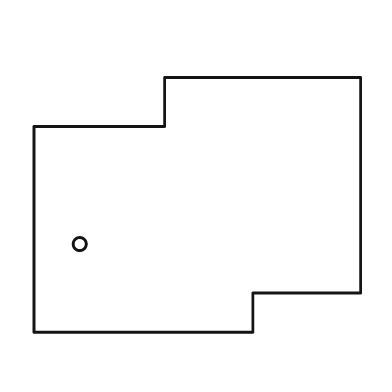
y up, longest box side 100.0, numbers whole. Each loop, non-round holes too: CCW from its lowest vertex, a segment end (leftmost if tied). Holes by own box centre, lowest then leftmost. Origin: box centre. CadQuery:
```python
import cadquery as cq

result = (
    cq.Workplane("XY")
    .moveTo(-50.0, -39.0)
    .lineTo(17.0, -39.0)
    .lineTo(17.0, -27.0)
    .lineTo(50.0, -27.0)
    .lineTo(50.0, 39.0)
    .lineTo(-10.0, 39.0)
    .lineTo(-10.0, 24.0)
    .lineTo(-50.0, 24.0)
    .close()
    .moveTo(-36.0, -12.0)
    .circle(2.0)
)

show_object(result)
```